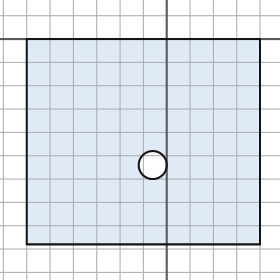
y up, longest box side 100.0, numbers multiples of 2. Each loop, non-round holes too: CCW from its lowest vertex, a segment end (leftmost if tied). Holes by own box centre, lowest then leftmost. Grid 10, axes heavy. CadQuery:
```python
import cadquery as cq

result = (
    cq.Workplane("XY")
    .moveTo(-60.0, -88.0)
    .lineTo(40.0, -88.0)
    .lineTo(40.0, 0.0)
    .lineTo(-60.0, 0.0)
    .close()
    .moveTo(-6.0, -54.0)
    .circle(6.0)
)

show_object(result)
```